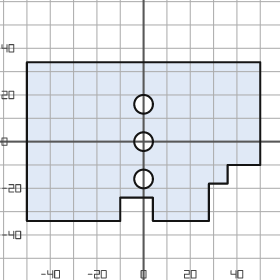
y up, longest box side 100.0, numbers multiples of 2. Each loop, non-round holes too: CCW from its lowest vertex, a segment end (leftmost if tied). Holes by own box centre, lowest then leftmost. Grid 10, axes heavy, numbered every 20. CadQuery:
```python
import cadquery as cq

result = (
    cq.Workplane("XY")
    .moveTo(-50.0, -34.0)
    .lineTo(-10.0, -34.0)
    .lineTo(-10.0, -24.0)
    .lineTo(4.0, -24.0)
    .lineTo(4.0, -34.0)
    .lineTo(28.0, -34.0)
    .lineTo(28.0, -18.0)
    .lineTo(36.0, -18.0)
    .lineTo(36.0, -10.0)
    .lineTo(50.0, -10.0)
    .lineTo(50.0, 34.0)
    .lineTo(-50.0, 34.0)
    .close()
    .moveTo(0.0, -16.0)
    .circle(4.0)
    .moveTo(0.0, 0.0)
    .circle(4.0)
    .moveTo(0.0, 16.0)
    .circle(4.0)
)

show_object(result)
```